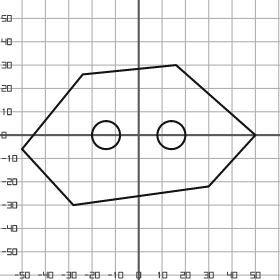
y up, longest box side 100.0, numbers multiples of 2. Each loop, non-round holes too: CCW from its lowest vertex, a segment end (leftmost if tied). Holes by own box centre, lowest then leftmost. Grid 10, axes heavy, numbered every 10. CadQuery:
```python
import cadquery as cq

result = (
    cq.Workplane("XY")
    .moveTo(-28.0, -30.0)
    .lineTo(30.0, -22.0)
    .lineTo(50.0, 0.0)
    .lineTo(16.0, 30.0)
    .lineTo(-24.0, 26.0)
    .lineTo(-50.0, -6.0)
    .close()
    .moveTo(-14.0, 0.0)
    .circle(6.0)
    .moveTo(14.0, 0.0)
    .circle(6.0)
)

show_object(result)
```